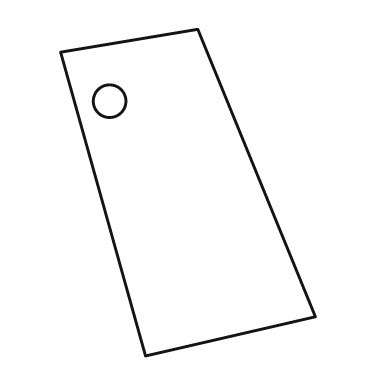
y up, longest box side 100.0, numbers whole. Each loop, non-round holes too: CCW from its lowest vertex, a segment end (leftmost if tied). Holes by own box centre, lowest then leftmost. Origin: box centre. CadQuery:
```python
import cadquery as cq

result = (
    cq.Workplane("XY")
    .moveTo(-13.0, -50.0)
    .lineTo(39.0, -38.0)
    .lineTo(3.0, 50.0)
    .lineTo(-39.0, 43.0)
    .close()
    .moveTo(-24.0, 28.0)
    .circle(5.0)
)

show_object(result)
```